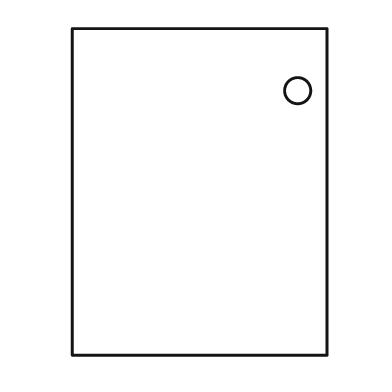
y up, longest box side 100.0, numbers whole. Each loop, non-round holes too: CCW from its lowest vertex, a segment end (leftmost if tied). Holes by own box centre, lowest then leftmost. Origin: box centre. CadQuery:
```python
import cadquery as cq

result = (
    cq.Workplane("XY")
    .moveTo(-39.0, -50.0)
    .lineTo(39.0, -50.0)
    .lineTo(39.0, 50.0)
    .lineTo(-39.0, 50.0)
    .close()
    .moveTo(30.0, 31.0)
    .circle(4.0)
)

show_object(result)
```